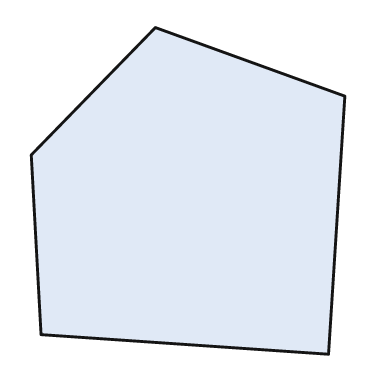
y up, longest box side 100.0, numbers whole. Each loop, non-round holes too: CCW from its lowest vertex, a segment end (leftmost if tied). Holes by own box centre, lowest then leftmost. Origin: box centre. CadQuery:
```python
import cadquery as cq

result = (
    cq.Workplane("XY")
    .moveTo(43.0, -50.0)
    .lineTo(48.0, 29.0)
    .lineTo(-10.0, 50.0)
    .lineTo(-48.0, 11.0)
    .lineTo(-45.0, -44.0)
    .close()
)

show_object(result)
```